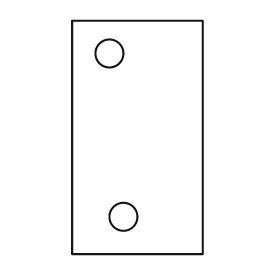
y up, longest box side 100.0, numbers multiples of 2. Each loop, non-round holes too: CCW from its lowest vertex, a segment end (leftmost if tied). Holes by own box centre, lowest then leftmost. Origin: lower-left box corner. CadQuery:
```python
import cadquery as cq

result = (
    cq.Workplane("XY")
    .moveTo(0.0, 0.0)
    .lineTo(56.0, 0.0)
    .lineTo(56.0, 100.0)
    .lineTo(0.0, 100.0)
    .close()
    .moveTo(22.0, 16.0)
    .circle(6.0)
    .moveTo(16.0, 86.0)
    .circle(6.0)
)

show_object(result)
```